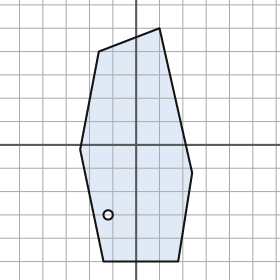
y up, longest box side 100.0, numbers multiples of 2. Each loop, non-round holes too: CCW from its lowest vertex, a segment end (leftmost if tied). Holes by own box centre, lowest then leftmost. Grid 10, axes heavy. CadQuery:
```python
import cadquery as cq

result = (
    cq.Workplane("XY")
    .moveTo(-14.0, -50.0)
    .lineTo(18.0, -50.0)
    .lineTo(24.0, -12.0)
    .lineTo(10.0, 50.0)
    .lineTo(-16.0, 40.0)
    .lineTo(-24.0, -2.0)
    .close()
    .moveTo(-12.0, -30.0)
    .circle(2.0)
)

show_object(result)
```